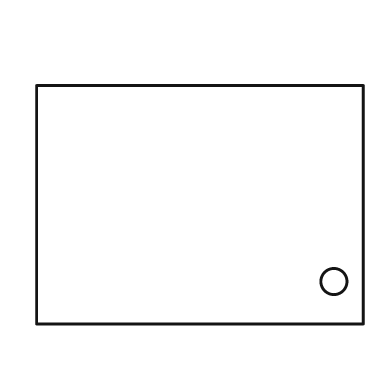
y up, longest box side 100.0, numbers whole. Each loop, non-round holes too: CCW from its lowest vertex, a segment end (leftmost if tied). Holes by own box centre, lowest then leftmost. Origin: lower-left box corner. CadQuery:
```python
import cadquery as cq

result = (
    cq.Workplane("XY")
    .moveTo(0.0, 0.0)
    .lineTo(100.0, 0.0)
    .lineTo(100.0, 73.0)
    .lineTo(0.0, 73.0)
    .close()
    .moveTo(91.0, 13.0)
    .circle(4.0)
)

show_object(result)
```